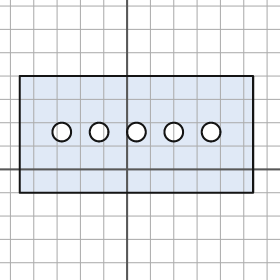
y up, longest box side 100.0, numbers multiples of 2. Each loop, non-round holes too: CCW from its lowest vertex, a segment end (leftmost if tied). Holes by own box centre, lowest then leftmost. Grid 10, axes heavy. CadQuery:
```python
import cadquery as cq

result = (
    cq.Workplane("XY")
    .moveTo(-46.0, -10.0)
    .lineTo(54.0, -10.0)
    .lineTo(54.0, 40.0)
    .lineTo(-46.0, 40.0)
    .close()
    .moveTo(-28.0, 16.0)
    .circle(4.0)
    .moveTo(-12.0, 16.0)
    .circle(4.0)
    .moveTo(4.0, 16.0)
    .circle(4.0)
    .moveTo(20.0, 16.0)
    .circle(4.0)
    .moveTo(36.0, 16.0)
    .circle(4.0)
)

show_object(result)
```